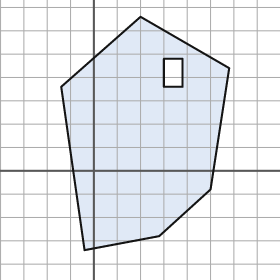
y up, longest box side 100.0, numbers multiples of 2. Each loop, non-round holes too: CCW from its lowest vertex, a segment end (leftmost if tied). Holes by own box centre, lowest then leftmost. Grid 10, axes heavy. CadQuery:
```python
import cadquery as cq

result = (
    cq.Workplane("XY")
    .moveTo(-4.0, -34.0)
    .lineTo(28.0, -28.0)
    .lineTo(50.0, -8.0)
    .lineTo(58.0, 44.0)
    .lineTo(20.0, 66.0)
    .lineTo(-14.0, 36.0)
    .close()
    .moveTo(30.0, 36.0)
    .lineTo(38.0, 36.0)
    .lineTo(38.0, 48.0)
    .lineTo(30.0, 48.0)
    .close()
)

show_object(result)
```